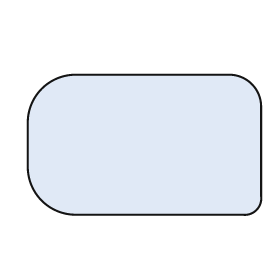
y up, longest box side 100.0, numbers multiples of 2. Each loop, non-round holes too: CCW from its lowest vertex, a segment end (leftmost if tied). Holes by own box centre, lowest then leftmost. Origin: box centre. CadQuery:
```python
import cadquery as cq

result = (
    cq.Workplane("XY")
    .moveTo(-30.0, -30.0)
    .lineTo(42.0, -30.0)
    .threePointArc((48.0, -28.0), (50.0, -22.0))
    .lineTo(50.0, 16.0)
    .threePointArc((46.0, 26.0), (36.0, 30.0))
    .lineTo(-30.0, 30.0)
    .threePointArc((-44.0, 24.0), (-50.0, 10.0))
    .lineTo(-50.0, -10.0)
    .threePointArc((-44.0, -24.0), (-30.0, -30.0))
    .close()
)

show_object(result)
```